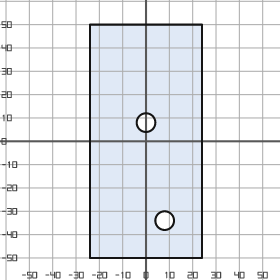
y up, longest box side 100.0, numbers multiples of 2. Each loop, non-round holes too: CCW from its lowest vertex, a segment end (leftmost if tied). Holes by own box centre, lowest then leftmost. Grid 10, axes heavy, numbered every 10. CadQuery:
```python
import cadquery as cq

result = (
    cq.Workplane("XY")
    .moveTo(-24.0, -50.0)
    .lineTo(24.0, -50.0)
    .lineTo(24.0, 50.0)
    .lineTo(-24.0, 50.0)
    .close()
    .moveTo(8.0, -34.0)
    .circle(4.0)
    .moveTo(0.0, 8.0)
    .circle(4.0)
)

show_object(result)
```